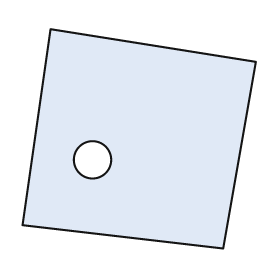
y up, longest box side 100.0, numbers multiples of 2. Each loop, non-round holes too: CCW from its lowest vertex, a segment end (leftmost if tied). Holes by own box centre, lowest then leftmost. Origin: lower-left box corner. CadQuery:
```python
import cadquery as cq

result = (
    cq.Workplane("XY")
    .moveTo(86.0, 0.0)
    .lineTo(100.0, 80.0)
    .lineTo(12.0, 94.0)
    .lineTo(0.0, 10.0)
    .close()
    .moveTo(30.0, 38.0)
    .circle(8.0)
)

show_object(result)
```